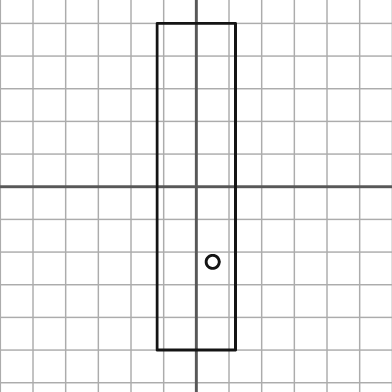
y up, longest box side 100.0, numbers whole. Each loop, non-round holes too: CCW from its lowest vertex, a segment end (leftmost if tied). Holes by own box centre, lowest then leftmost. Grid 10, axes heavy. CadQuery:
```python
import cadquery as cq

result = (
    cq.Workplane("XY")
    .moveTo(-12.0, -50.0)
    .lineTo(12.0, -50.0)
    .lineTo(12.0, 50.0)
    .lineTo(-12.0, 50.0)
    .close()
    .moveTo(5.0, -23.0)
    .circle(2.0)
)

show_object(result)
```